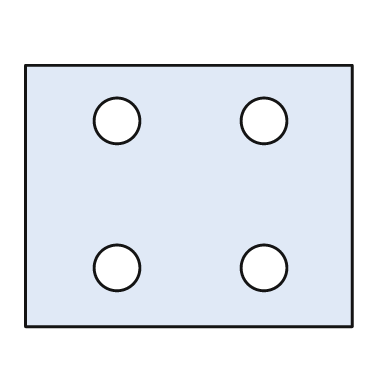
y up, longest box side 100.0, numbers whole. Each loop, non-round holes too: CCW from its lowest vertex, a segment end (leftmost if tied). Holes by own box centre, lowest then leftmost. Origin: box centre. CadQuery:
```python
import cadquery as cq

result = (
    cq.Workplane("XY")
    .moveTo(-50.0, -40.0)
    .lineTo(50.0, -40.0)
    .lineTo(50.0, 40.0)
    .lineTo(-50.0, 40.0)
    .close()
    .moveTo(-22.0, -22.0)
    .circle(7.0)
    .moveTo(23.0, -22.0)
    .circle(7.0)
    .moveTo(-22.0, 23.0)
    .circle(7.0)
    .moveTo(23.0, 23.0)
    .circle(7.0)
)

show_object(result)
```